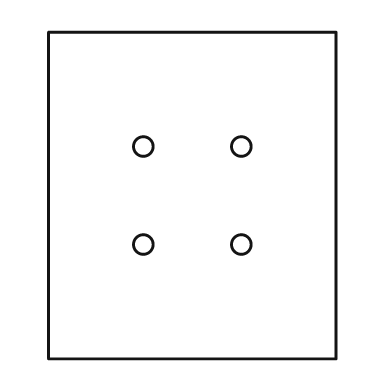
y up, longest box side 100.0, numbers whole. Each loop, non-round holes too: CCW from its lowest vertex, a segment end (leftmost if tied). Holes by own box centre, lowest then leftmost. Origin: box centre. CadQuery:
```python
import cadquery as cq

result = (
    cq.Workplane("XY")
    .moveTo(-44.0, -50.0)
    .lineTo(44.0, -50.0)
    .lineTo(44.0, 50.0)
    .lineTo(-44.0, 50.0)
    .close()
    .moveTo(-15.0, -15.0)
    .circle(3.0)
    .moveTo(15.0, -15.0)
    .circle(3.0)
    .moveTo(-15.0, 15.0)
    .circle(3.0)
    .moveTo(15.0, 15.0)
    .circle(3.0)
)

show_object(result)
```